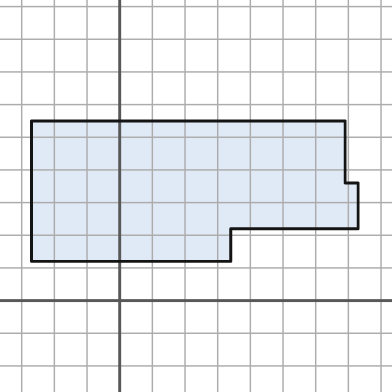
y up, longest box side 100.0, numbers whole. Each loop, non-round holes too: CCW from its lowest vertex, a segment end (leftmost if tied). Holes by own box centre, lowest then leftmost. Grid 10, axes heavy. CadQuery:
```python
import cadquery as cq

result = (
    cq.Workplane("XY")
    .moveTo(-27.0, 12.0)
    .lineTo(34.0, 12.0)
    .lineTo(34.0, 22.0)
    .lineTo(73.0, 22.0)
    .lineTo(73.0, 36.0)
    .lineTo(69.0, 36.0)
    .lineTo(69.0, 55.0)
    .lineTo(-27.0, 55.0)
    .close()
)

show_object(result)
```